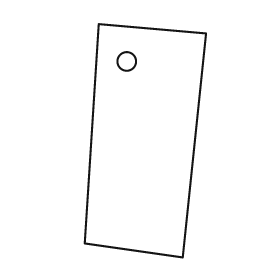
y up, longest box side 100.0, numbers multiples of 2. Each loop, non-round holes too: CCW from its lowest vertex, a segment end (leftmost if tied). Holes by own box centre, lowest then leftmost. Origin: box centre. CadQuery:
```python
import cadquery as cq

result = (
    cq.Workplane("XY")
    .moveTo(16.0, -50.0)
    .lineTo(26.0, 46.0)
    .lineTo(-20.0, 50.0)
    .lineTo(-26.0, -44.0)
    .close()
    .moveTo(-8.0, 34.0)
    .circle(4.0)
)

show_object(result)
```